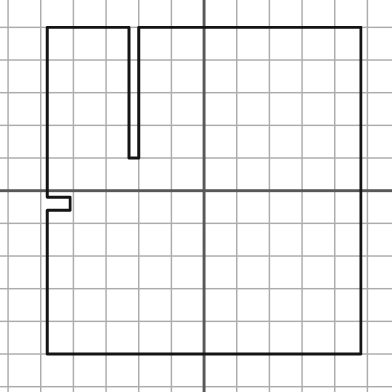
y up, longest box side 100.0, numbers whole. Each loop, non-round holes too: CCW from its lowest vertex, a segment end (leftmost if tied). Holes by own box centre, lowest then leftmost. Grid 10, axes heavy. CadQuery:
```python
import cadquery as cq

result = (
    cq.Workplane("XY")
    .moveTo(-48.0, -50.0)
    .lineTo(48.0, -50.0)
    .lineTo(48.0, 50.0)
    .lineTo(-20.0, 50.0)
    .lineTo(-20.0, 10.0)
    .lineTo(-23.0, 10.0)
    .lineTo(-23.0, 50.0)
    .lineTo(-48.0, 50.0)
    .lineTo(-48.0, -2.0)
    .lineTo(-41.0, -2.0)
    .lineTo(-41.0, -6.0)
    .lineTo(-48.0, -6.0)
    .close()
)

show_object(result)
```